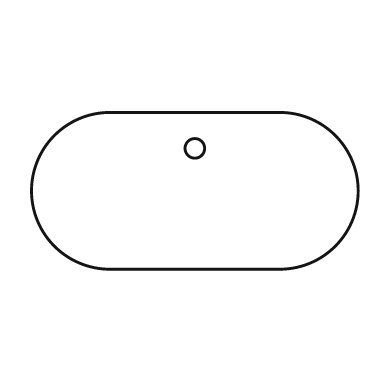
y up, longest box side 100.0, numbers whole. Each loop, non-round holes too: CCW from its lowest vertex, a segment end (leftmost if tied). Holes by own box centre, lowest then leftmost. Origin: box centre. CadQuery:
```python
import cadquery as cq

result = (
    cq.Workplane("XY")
    .moveTo(-26.0, -24.0)
    .lineTo(26.0, -24.0)
    .threePointArc((50.0, 0.0), (26.0, 24.0))
    .lineTo(-26.0, 24.0)
    .threePointArc((-50.0, 0.0), (-26.0, -24.0))
    .close()
    .moveTo(0.0, 13.0)
    .circle(3.0)
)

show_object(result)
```